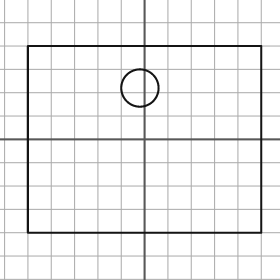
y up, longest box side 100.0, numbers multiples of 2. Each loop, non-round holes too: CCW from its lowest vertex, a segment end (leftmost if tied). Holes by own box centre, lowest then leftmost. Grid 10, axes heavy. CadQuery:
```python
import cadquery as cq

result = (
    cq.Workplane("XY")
    .moveTo(-50.0, -40.0)
    .lineTo(50.0, -40.0)
    .lineTo(50.0, 40.0)
    .lineTo(-50.0, 40.0)
    .close()
    .moveTo(-2.0, 22.0)
    .circle(8.0)
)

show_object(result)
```